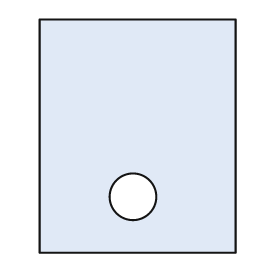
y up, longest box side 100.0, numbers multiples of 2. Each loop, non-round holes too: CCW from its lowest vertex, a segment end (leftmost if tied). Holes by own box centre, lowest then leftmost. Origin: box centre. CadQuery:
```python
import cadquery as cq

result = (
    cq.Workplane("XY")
    .moveTo(-42.0, -50.0)
    .lineTo(42.0, -50.0)
    .lineTo(42.0, 50.0)
    .lineTo(-42.0, 50.0)
    .close()
    .moveTo(-2.0, -26.0)
    .circle(10.0)
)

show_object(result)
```